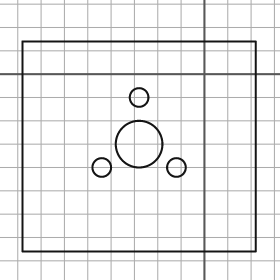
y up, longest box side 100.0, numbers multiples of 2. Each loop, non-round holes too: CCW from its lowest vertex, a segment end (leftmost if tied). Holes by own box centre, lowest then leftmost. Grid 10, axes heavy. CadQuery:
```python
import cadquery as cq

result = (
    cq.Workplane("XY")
    .moveTo(-78.0, -76.0)
    .lineTo(22.0, -76.0)
    .lineTo(22.0, 14.0)
    .lineTo(-78.0, 14.0)
    .close()
    .moveTo(-44.0, -40.0)
    .circle(4.0)
    .moveTo(-12.0, -40.0)
    .circle(4.0)
    .moveTo(-28.0, -30.0)
    .circle(10.0)
    .moveTo(-28.0, -10.0)
    .circle(4.0)
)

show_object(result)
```